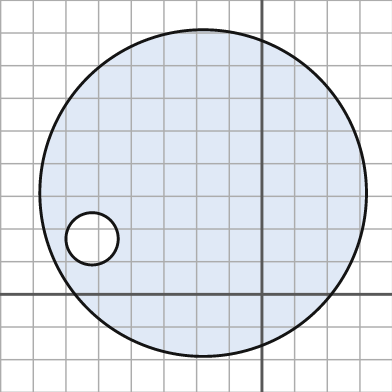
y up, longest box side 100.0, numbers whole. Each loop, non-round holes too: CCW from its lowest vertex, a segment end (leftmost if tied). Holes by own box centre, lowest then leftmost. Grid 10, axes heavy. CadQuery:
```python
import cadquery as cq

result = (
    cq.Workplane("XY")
    .moveTo(-18.0, 31.0)
    .circle(50.0)
    .moveTo(-52.0, 17.0)
    .circle(8.0)
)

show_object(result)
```